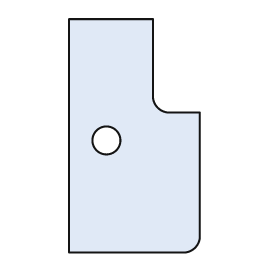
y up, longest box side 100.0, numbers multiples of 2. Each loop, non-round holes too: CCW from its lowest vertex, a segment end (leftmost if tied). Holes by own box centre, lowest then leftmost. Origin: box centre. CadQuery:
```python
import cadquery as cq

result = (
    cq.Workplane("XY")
    .moveTo(-28.0, -50.0)
    .lineTo(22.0, -50.0)
    .threePointArc((26.0, -48.0), (28.0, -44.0))
    .lineTo(28.0, 10.0)
    .lineTo(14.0, 10.0)
    .threePointArc((10.0, 12.0), (8.0, 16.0))
    .lineTo(8.0, 50.0)
    .lineTo(-28.0, 50.0)
    .close()
    .moveTo(-12.0, -2.0)
    .circle(6.0)
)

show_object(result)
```